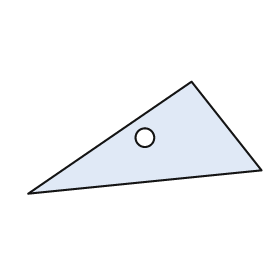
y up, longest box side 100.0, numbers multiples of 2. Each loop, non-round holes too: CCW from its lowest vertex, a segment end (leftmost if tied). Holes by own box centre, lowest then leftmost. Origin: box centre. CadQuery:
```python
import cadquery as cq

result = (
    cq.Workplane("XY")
    .moveTo(-50.0, -24.0)
    .lineTo(50.0, -14.0)
    .lineTo(20.0, 24.0)
    .close()
    .moveTo(0.0, 0.0)
    .circle(4.0)
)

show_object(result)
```